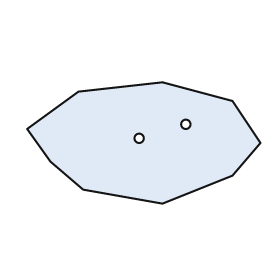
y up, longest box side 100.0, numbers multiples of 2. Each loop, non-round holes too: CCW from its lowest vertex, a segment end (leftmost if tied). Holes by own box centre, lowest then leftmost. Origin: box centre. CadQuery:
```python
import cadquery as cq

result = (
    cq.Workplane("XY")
    .moveTo(8.0, -26.0)
    .lineTo(38.0, -14.0)
    .lineTo(50.0, 0.0)
    .lineTo(38.0, 18.0)
    .lineTo(8.0, 26.0)
    .lineTo(-28.0, 22.0)
    .lineTo(-50.0, 6.0)
    .lineTo(-40.0, -8.0)
    .lineTo(-26.0, -20.0)
    .close()
    .moveTo(-2.0, 2.0)
    .circle(2.0)
    .moveTo(18.0, 8.0)
    .circle(2.0)
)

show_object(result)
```